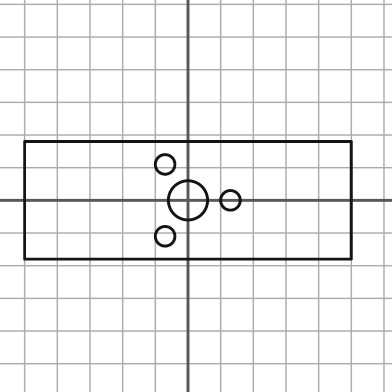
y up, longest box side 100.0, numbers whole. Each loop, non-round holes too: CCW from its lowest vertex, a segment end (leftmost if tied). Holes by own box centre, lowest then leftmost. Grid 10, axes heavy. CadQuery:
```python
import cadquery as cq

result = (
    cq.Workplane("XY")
    .moveTo(-50.0, -18.0)
    .lineTo(50.0, -18.0)
    .lineTo(50.0, 18.0)
    .lineTo(-50.0, 18.0)
    .close()
    .moveTo(-7.0, -11.0)
    .circle(3.0)
    .moveTo(0.0, 0.0)
    .circle(6.0)
    .moveTo(13.0, 0.0)
    .circle(3.0)
    .moveTo(-7.0, 11.0)
    .circle(3.0)
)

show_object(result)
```